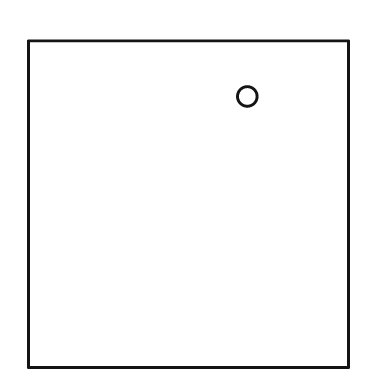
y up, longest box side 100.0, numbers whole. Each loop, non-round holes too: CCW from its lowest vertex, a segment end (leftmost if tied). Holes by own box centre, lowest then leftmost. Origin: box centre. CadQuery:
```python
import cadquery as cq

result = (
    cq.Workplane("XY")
    .moveTo(-49.0, -50.0)
    .lineTo(49.0, -50.0)
    .lineTo(49.0, 50.0)
    .lineTo(-49.0, 50.0)
    .close()
    .moveTo(18.0, 33.0)
    .circle(3.0)
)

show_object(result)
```